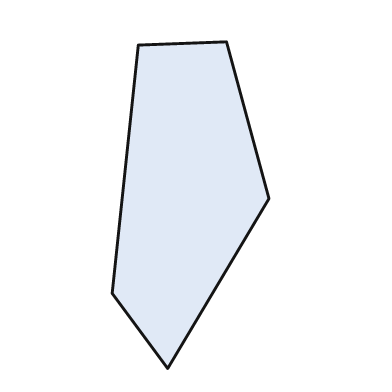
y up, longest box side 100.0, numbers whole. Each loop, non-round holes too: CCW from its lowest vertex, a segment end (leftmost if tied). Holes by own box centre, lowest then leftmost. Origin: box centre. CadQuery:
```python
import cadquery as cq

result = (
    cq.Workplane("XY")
    .moveTo(-7.0, -50.0)
    .lineTo(24.0, 2.0)
    .lineTo(11.0, 50.0)
    .lineTo(-16.0, 49.0)
    .lineTo(-24.0, -27.0)
    .close()
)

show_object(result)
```